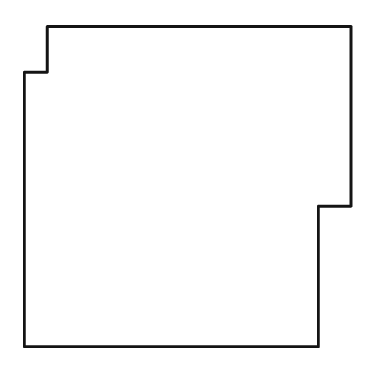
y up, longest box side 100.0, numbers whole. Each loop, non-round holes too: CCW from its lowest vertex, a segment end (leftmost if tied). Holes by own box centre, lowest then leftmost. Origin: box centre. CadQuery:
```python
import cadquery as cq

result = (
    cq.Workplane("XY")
    .moveTo(-50.0, -49.0)
    .lineTo(40.0, -49.0)
    .lineTo(40.0, -6.0)
    .lineTo(50.0, -6.0)
    .lineTo(50.0, 49.0)
    .lineTo(-43.0, 49.0)
    .lineTo(-43.0, 35.0)
    .lineTo(-50.0, 35.0)
    .close()
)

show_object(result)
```